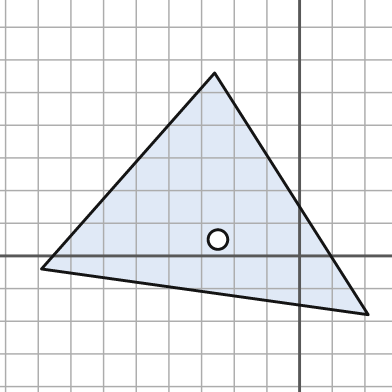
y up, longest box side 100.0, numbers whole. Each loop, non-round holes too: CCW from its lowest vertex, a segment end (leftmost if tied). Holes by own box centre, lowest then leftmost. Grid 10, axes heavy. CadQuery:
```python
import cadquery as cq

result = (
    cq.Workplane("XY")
    .moveTo(21.0, -18.0)
    .lineTo(-26.0, 56.0)
    .lineTo(-79.0, -4.0)
    .close()
    .moveTo(-25.0, 5.0)
    .circle(3.0)
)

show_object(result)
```